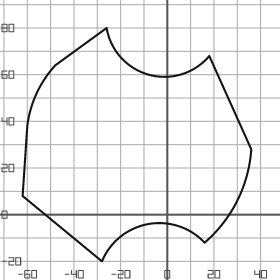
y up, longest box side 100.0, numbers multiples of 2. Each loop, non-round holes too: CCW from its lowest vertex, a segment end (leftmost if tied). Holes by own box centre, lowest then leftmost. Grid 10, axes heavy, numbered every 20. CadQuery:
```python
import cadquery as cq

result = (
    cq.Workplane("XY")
    .moveTo(-28.0, -20.0)
    .threePointArc((-8.0, -4.0), (16.0, -12.0))
    .threePointArc((30.0, 6.0), (36.0, 28.0))
    .lineTo(18.0, 68.0)
    .threePointArc((-8.0, 60.0), (-26.0, 80.0))
    .lineTo(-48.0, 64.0)
    .threePointArc((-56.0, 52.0), (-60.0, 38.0))
    .lineTo(-62.0, 8.0)
    .close()
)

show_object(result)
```